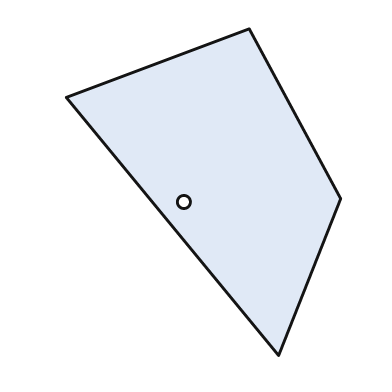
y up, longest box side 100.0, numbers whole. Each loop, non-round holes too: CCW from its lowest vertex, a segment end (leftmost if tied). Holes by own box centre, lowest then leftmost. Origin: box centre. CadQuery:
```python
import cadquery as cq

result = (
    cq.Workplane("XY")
    .moveTo(23.0, -50.0)
    .lineTo(42.0, -2.0)
    .lineTo(14.0, 50.0)
    .lineTo(-42.0, 29.0)
    .close()
    .moveTo(-6.0, -3.0)
    .circle(2.0)
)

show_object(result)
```